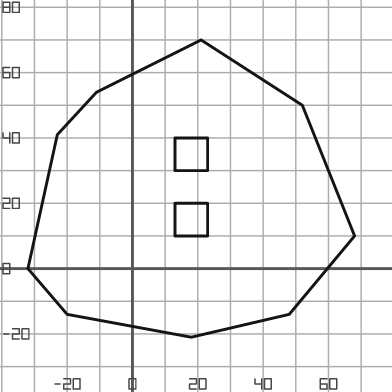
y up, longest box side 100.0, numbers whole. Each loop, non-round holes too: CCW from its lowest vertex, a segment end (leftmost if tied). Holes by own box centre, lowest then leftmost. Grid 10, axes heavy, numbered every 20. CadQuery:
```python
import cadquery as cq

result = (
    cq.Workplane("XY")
    .moveTo(18.0, -21.0)
    .lineTo(48.0, -14.0)
    .lineTo(68.0, 10.0)
    .lineTo(52.0, 50.0)
    .lineTo(21.0, 70.0)
    .lineTo(-11.0, 54.0)
    .lineTo(-23.0, 41.0)
    .lineTo(-32.0, 0.0)
    .lineTo(-20.0, -14.0)
    .close()
    .moveTo(13.0, 10.0)
    .lineTo(23.0, 10.0)
    .lineTo(23.0, 20.0)
    .lineTo(13.0, 20.0)
    .close()
    .moveTo(13.0, 30.0)
    .lineTo(23.0, 30.0)
    .lineTo(23.0, 40.0)
    .lineTo(13.0, 40.0)
    .close()
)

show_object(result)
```